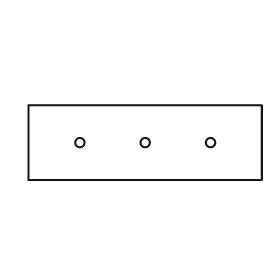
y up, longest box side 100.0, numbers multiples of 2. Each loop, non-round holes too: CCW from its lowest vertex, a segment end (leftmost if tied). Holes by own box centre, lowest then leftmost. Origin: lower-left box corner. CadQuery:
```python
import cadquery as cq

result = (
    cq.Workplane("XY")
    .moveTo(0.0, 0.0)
    .lineTo(100.0, 0.0)
    .lineTo(100.0, 32.0)
    .lineTo(0.0, 32.0)
    .close()
    .moveTo(22.0, 16.0)
    .circle(2.0)
    .moveTo(50.0, 16.0)
    .circle(2.0)
    .moveTo(78.0, 16.0)
    .circle(2.0)
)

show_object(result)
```